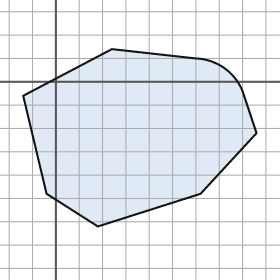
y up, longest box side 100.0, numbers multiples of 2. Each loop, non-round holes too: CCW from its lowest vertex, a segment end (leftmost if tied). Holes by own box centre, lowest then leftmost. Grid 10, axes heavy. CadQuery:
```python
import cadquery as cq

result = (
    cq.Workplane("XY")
    .moveTo(18.0, -62.0)
    .lineTo(62.0, -48.0)
    .lineTo(86.0, -22.0)
    .lineTo(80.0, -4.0)
    .threePointArc((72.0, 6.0), (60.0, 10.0))
    .lineTo(24.0, 14.0)
    .lineTo(-14.0, -6.0)
    .lineTo(-4.0, -48.0)
    .close()
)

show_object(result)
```